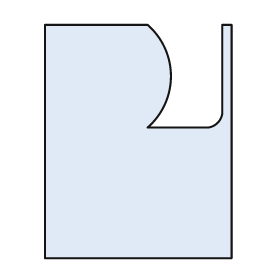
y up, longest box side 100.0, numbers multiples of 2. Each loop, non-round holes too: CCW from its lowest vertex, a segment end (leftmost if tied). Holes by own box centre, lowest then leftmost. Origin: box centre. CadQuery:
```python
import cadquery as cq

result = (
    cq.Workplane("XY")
    .moveTo(-40.0, -50.0)
    .lineTo(40.0, -50.0)
    .lineTo(40.0, 50.0)
    .lineTo(36.0, 50.0)
    .lineTo(36.0, 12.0)
    .threePointArc((34.0, 8.0), (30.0, 6.0))
    .lineTo(4.0, 6.0)
    .threePointArc((14.0, 28.0), (4.0, 50.0))
    .lineTo(-40.0, 50.0)
    .close()
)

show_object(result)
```